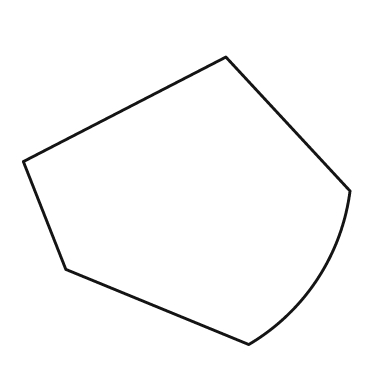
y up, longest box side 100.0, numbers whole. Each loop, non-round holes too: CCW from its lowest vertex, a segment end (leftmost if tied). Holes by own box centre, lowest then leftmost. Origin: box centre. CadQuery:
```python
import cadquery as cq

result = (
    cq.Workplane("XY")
    .moveTo(19.0, -44.0)
    .threePointArc((40.0, -24.0), (50.0, 3.0))
    .lineTo(12.0, 44.0)
    .lineTo(-50.0, 12.0)
    .lineTo(-37.0, -21.0)
    .close()
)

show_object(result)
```